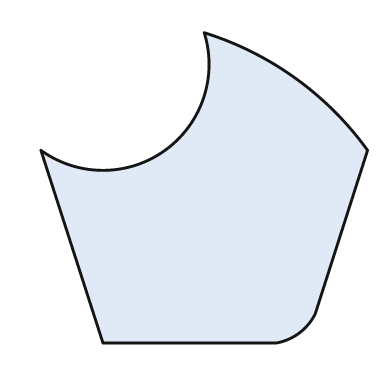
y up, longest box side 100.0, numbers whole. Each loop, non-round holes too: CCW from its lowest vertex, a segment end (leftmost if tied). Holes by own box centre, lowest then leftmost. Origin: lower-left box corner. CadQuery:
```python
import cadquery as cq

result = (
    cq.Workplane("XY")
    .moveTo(19.0, 0.0)
    .lineTo(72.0, 0.0)
    .threePointArc((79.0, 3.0), (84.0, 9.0))
    .lineTo(100.0, 59.0)
    .threePointArc((78.0, 81.0), (50.0, 95.0))
    .threePointArc((38.0, 59.0), (0.0, 59.0))
    .close()
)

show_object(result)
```